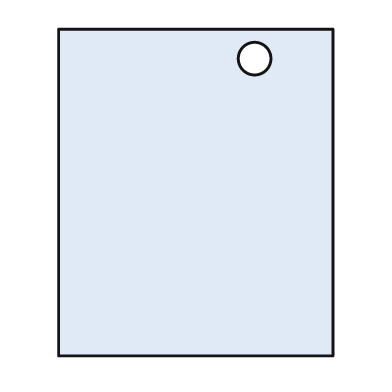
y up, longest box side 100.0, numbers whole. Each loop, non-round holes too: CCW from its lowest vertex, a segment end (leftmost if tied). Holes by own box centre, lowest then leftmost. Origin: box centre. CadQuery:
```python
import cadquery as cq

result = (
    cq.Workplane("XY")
    .moveTo(-42.0, -50.0)
    .lineTo(42.0, -50.0)
    .lineTo(42.0, 50.0)
    .lineTo(-42.0, 50.0)
    .close()
    .moveTo(18.0, 41.0)
    .circle(5.0)
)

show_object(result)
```